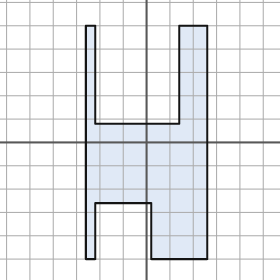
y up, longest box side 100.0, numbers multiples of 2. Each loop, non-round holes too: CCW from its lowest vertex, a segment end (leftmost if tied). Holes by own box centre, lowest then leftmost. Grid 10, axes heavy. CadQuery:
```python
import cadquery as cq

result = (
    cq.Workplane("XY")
    .moveTo(-26.0, -50.0)
    .lineTo(-22.0, -50.0)
    .lineTo(-22.0, -26.0)
    .lineTo(2.0, -26.0)
    .lineTo(2.0, -50.0)
    .lineTo(26.0, -50.0)
    .lineTo(26.0, 50.0)
    .lineTo(14.0, 50.0)
    .lineTo(14.0, 8.0)
    .lineTo(-22.0, 8.0)
    .lineTo(-22.0, 50.0)
    .lineTo(-26.0, 50.0)
    .close()
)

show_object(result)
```